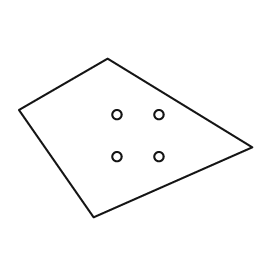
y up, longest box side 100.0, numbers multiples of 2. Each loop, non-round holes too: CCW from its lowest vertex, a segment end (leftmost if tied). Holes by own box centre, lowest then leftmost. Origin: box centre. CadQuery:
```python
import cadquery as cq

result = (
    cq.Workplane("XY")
    .moveTo(-18.0, -34.0)
    .lineTo(50.0, -4.0)
    .lineTo(-12.0, 34.0)
    .lineTo(-50.0, 12.0)
    .close()
    .moveTo(-8.0, -8.0)
    .circle(2.0)
    .moveTo(10.0, -8.0)
    .circle(2.0)
    .moveTo(-8.0, 10.0)
    .circle(2.0)
    .moveTo(10.0, 10.0)
    .circle(2.0)
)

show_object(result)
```